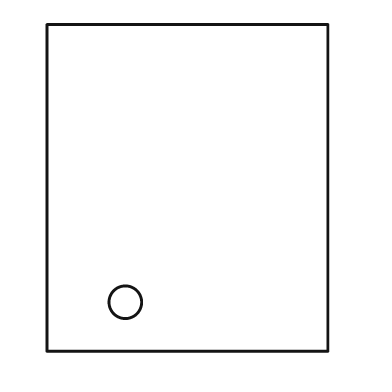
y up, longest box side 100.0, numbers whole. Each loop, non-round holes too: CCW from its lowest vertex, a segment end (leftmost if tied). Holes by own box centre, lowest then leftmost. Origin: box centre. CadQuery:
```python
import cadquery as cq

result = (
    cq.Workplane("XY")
    .moveTo(-43.0, -50.0)
    .lineTo(43.0, -50.0)
    .lineTo(43.0, 50.0)
    .lineTo(-43.0, 50.0)
    .close()
    .moveTo(-19.0, -35.0)
    .circle(5.0)
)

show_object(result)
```